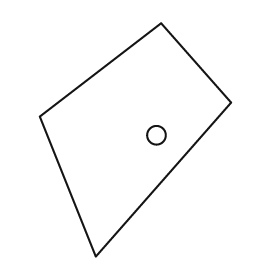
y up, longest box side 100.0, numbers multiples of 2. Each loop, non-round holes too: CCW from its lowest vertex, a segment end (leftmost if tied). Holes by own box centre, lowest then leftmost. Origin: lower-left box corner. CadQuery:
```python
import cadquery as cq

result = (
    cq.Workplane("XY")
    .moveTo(24.0, 0.0)
    .lineTo(82.0, 66.0)
    .lineTo(52.0, 100.0)
    .lineTo(0.0, 60.0)
    .close()
    .moveTo(50.0, 52.0)
    .circle(4.0)
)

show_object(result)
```